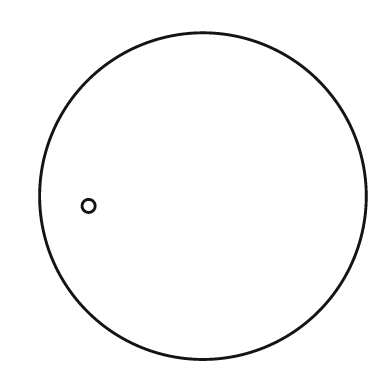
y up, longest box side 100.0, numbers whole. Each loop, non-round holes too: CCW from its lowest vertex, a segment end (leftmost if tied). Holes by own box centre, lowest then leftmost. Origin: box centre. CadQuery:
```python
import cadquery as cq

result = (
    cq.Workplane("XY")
    .moveTo(0.0, 0.0)
    .circle(50.0)
    .moveTo(-35.0, -3.0)
    .circle(2.0)
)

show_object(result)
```